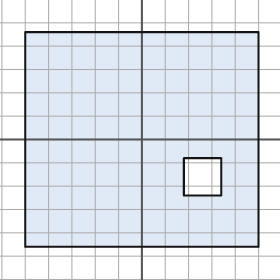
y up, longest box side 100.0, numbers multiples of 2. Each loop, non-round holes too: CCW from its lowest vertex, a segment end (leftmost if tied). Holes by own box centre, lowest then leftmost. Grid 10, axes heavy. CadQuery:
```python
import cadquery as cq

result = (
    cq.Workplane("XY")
    .moveTo(-50.0, -46.0)
    .lineTo(50.0, -46.0)
    .lineTo(50.0, 46.0)
    .lineTo(-50.0, 46.0)
    .close()
    .moveTo(18.0, -24.0)
    .lineTo(34.0, -24.0)
    .lineTo(34.0, -8.0)
    .lineTo(18.0, -8.0)
    .close()
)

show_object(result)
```